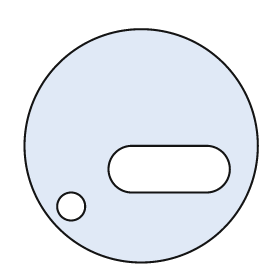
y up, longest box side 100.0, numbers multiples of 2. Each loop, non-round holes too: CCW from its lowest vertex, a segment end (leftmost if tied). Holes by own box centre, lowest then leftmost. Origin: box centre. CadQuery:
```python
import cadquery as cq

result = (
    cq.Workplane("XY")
    .moveTo(0.0, 0.0)
    .circle(50.0)
    .moveTo(-30.0, -26.0)
    .circle(6.0)
    .moveTo(-4.0, -20.0)
    .lineTo(28.0, -20.0)
    .threePointArc((38.0, -10.0), (28.0, 0.0))
    .lineTo(-4.0, 0.0)
    .threePointArc((-14.0, -10.0), (-4.0, -20.0))
    .close()
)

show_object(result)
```